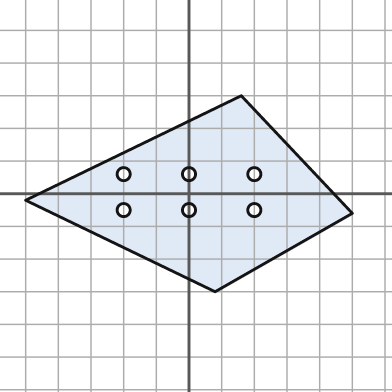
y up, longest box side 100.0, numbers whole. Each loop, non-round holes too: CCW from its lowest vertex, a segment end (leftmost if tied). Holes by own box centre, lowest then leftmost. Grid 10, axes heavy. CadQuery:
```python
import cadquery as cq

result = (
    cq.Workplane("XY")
    .moveTo(8.0, -30.0)
    .lineTo(50.0, -6.0)
    .lineTo(16.0, 30.0)
    .lineTo(-50.0, -2.0)
    .close()
    .moveTo(-20.0, -5.0)
    .circle(2.0)
    .moveTo(0.0, -5.0)
    .circle(2.0)
    .moveTo(20.0, -5.0)
    .circle(2.0)
    .moveTo(-20.0, 6.0)
    .circle(2.0)
    .moveTo(0.0, 6.0)
    .circle(2.0)
    .moveTo(20.0, 6.0)
    .circle(2.0)
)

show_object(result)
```